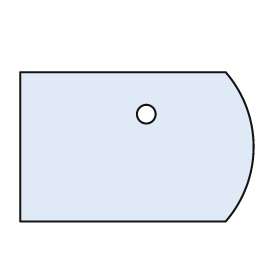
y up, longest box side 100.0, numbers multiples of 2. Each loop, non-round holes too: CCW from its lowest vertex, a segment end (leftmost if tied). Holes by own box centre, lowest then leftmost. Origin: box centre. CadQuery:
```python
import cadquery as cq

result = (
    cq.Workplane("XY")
    .moveTo(-50.0, -32.0)
    .lineTo(38.0, -32.0)
    .threePointArc((50.0, 0.0), (38.0, 32.0))
    .lineTo(-50.0, 32.0)
    .close()
    .moveTo(4.0, 14.0)
    .circle(4.0)
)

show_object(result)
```